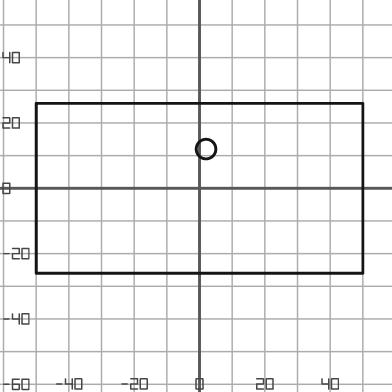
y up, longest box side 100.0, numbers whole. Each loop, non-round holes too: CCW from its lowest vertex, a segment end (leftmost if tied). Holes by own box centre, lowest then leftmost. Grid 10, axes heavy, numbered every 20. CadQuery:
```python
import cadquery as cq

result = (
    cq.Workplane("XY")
    .moveTo(-50.0, -26.0)
    .lineTo(50.0, -26.0)
    .lineTo(50.0, 26.0)
    .lineTo(-50.0, 26.0)
    .close()
    .moveTo(2.0, 12.0)
    .circle(3.0)
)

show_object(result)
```